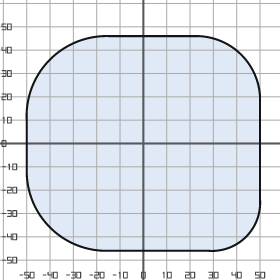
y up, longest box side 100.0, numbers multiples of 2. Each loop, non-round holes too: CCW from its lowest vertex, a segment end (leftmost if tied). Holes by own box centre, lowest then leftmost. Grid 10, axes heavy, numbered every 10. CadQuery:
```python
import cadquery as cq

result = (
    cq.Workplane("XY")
    .moveTo(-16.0, -46.0)
    .lineTo(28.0, -46.0)
    .threePointArc((44.0, -40.0), (50.0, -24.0))
    .lineTo(50.0, 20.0)
    .threePointArc((42.0, 38.0), (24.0, 46.0))
    .lineTo(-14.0, 46.0)
    .threePointArc((-40.0, 36.0), (-50.0, 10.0))
    .lineTo(-50.0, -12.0)
    .threePointArc((-40.0, -36.0), (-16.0, -46.0))
    .close()
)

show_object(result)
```